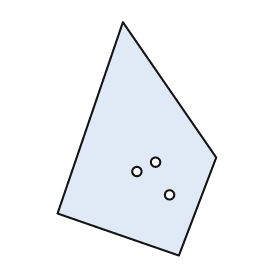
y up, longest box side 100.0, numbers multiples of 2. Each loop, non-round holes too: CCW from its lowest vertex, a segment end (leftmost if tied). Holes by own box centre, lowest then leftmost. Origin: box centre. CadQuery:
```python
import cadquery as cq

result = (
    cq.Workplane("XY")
    .moveTo(18.0, -50.0)
    .lineTo(34.0, -8.0)
    .lineTo(-6.0, 50.0)
    .lineTo(-34.0, -32.0)
    .close()
    .moveTo(14.0, -24.0)
    .circle(2.0)
    .moveTo(0.0, -14.0)
    .circle(2.0)
    .moveTo(8.0, -10.0)
    .circle(2.0)
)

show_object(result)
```